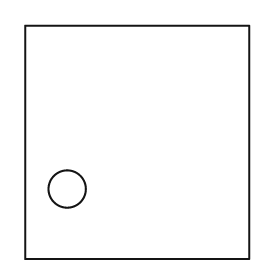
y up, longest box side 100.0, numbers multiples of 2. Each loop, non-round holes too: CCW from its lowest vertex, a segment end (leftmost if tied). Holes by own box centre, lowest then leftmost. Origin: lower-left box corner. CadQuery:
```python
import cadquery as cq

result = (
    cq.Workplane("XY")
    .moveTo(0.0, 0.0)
    .lineTo(96.0, 0.0)
    .lineTo(96.0, 100.0)
    .lineTo(0.0, 100.0)
    .close()
    .moveTo(18.0, 30.0)
    .circle(8.0)
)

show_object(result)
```